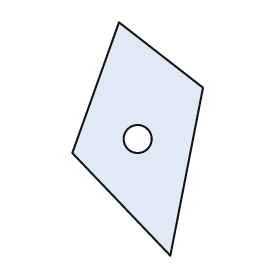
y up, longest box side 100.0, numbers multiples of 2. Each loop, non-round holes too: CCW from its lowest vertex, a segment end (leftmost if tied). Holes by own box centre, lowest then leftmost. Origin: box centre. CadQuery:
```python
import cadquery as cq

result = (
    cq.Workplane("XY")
    .moveTo(14.0, -50.0)
    .lineTo(28.0, 22.0)
    .lineTo(-8.0, 50.0)
    .lineTo(-28.0, -6.0)
    .close()
    .moveTo(0.0, 0.0)
    .circle(6.0)
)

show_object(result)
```